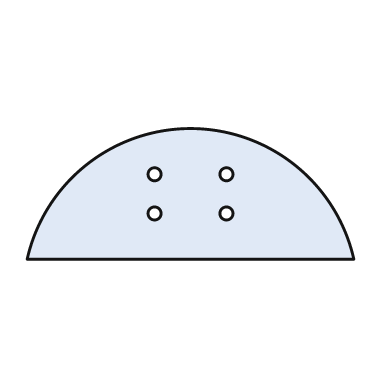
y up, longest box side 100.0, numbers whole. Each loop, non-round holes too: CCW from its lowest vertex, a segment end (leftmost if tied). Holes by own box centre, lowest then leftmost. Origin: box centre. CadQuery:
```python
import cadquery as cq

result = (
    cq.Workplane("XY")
    .moveTo(-50.0, -20.0)
    .lineTo(50.0, -20.0)
    .threePointArc((0.0, 20.0), (-50.0, -20.0))
    .close()
    .moveTo(-11.0, -6.0)
    .circle(2.0)
    .moveTo(11.0, -6.0)
    .circle(2.0)
    .moveTo(-11.0, 6.0)
    .circle(2.0)
    .moveTo(11.0, 6.0)
    .circle(2.0)
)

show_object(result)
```